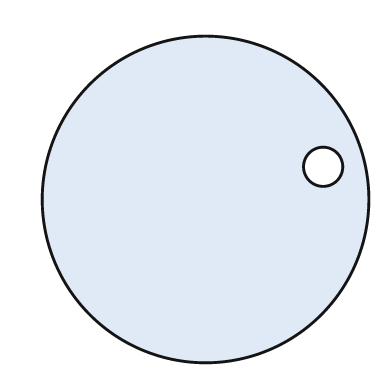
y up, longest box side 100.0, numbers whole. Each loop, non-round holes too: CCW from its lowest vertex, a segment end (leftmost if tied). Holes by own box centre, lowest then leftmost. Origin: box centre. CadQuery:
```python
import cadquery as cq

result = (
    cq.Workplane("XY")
    .moveTo(0.0, 0.0)
    .circle(50.0)
    .moveTo(36.0, 10.0)
    .circle(6.0)
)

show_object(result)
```